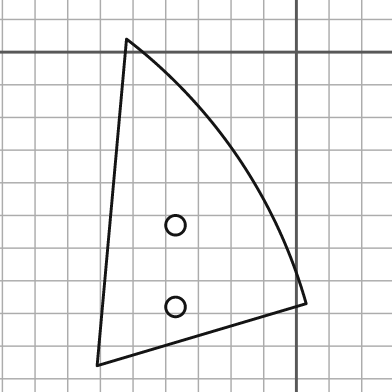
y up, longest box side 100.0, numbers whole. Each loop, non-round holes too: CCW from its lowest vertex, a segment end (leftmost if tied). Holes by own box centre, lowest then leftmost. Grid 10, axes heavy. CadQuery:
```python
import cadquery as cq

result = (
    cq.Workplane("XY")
    .moveTo(-61.0, -96.0)
    .lineTo(3.0, -77.0)
    .threePointArc((-18.0, -32.0), (-52.0, 4.0))
    .close()
    .moveTo(-37.0, -78.0)
    .circle(3.0)
    .moveTo(-37.0, -53.0)
    .circle(3.0)
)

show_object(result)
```